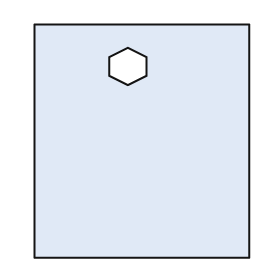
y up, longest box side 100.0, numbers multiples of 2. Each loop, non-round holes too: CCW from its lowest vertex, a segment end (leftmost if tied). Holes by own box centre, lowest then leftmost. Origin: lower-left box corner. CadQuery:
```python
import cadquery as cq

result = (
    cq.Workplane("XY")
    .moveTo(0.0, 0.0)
    .lineTo(92.0, 0.0)
    .lineTo(92.0, 100.0)
    .lineTo(0.0, 100.0)
    .close()
    .moveTo(40.0, 74.0)
    .lineTo(48.0, 78.0)
    .lineTo(48.0, 86.0)
    .lineTo(40.0, 90.0)
    .lineTo(32.0, 86.0)
    .lineTo(32.0, 78.0)
    .close()
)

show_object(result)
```